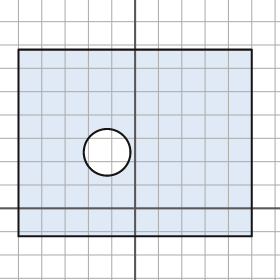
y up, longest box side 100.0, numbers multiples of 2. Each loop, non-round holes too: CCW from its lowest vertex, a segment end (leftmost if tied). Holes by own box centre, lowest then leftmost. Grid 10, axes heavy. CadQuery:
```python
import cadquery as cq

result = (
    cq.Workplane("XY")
    .moveTo(-50.0, -12.0)
    .lineTo(50.0, -12.0)
    .lineTo(50.0, 68.0)
    .lineTo(-50.0, 68.0)
    .close()
    .moveTo(-12.0, 24.0)
    .circle(10.0)
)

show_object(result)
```